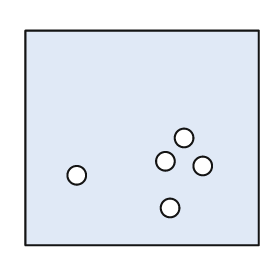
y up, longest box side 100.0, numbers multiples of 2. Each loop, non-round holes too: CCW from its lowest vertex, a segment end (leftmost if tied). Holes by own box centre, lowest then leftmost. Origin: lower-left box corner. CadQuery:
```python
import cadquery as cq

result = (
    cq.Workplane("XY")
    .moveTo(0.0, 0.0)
    .lineTo(100.0, 0.0)
    .lineTo(100.0, 92.0)
    .lineTo(0.0, 92.0)
    .close()
    .moveTo(62.0, 16.0)
    .circle(4.0)
    .moveTo(22.0, 30.0)
    .circle(4.0)
    .moveTo(76.0, 34.0)
    .circle(4.0)
    .moveTo(60.0, 36.0)
    .circle(4.0)
    .moveTo(68.0, 46.0)
    .circle(4.0)
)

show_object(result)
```